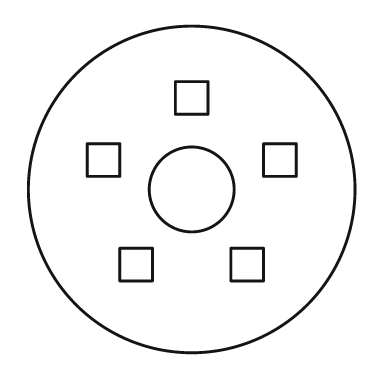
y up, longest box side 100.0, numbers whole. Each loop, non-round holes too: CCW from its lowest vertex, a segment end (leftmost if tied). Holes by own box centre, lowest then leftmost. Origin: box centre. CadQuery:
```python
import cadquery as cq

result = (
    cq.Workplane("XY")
    .moveTo(0.0, 0.0)
    .circle(50.0)
    .moveTo(-22.0, -28.0)
    .lineTo(-12.0, -28.0)
    .lineTo(-12.0, -18.0)
    .lineTo(-22.0, -18.0)
    .close()
    .moveTo(12.0, -28.0)
    .lineTo(22.0, -28.0)
    .lineTo(22.0, -18.0)
    .lineTo(12.0, -18.0)
    .close()
    .moveTo(0.0, 0.0)
    .circle(13.0)
    .moveTo(-32.0, 4.0)
    .lineTo(-22.0, 4.0)
    .lineTo(-22.0, 14.0)
    .lineTo(-32.0, 14.0)
    .close()
    .moveTo(22.0, 4.0)
    .lineTo(32.0, 4.0)
    .lineTo(32.0, 14.0)
    .lineTo(22.0, 14.0)
    .close()
    .moveTo(-5.0, 23.0)
    .lineTo(5.0, 23.0)
    .lineTo(5.0, 33.0)
    .lineTo(-5.0, 33.0)
    .close()
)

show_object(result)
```